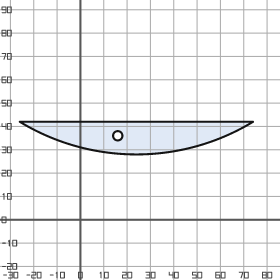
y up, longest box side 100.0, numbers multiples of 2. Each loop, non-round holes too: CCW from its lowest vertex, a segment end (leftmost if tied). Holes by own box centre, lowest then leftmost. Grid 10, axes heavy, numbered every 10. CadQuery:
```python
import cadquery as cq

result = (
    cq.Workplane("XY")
    .moveTo(-26.0, 42.0)
    .threePointArc((24.0, 28.0), (74.0, 42.0))
    .close()
    .moveTo(16.0, 36.0)
    .circle(2.0)
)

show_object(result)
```